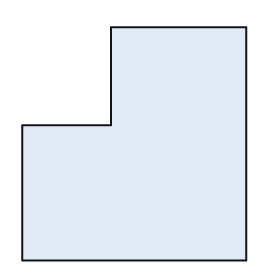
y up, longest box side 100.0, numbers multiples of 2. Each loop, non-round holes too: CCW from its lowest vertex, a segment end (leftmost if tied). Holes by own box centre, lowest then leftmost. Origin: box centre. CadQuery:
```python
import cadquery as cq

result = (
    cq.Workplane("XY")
    .moveTo(-48.0, -50.0)
    .lineTo(48.0, -50.0)
    .lineTo(48.0, 50.0)
    .lineTo(-10.0, 50.0)
    .lineTo(-10.0, 8.0)
    .lineTo(-48.0, 8.0)
    .close()
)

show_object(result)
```